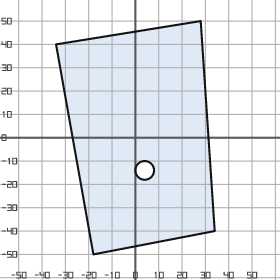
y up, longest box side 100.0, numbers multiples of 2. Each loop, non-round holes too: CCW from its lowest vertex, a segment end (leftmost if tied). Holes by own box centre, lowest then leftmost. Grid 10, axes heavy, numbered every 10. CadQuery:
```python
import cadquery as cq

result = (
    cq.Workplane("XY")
    .moveTo(-18.0, -50.0)
    .lineTo(34.0, -40.0)
    .lineTo(28.0, 50.0)
    .lineTo(-34.0, 40.0)
    .close()
    .moveTo(4.0, -14.0)
    .circle(4.0)
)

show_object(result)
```